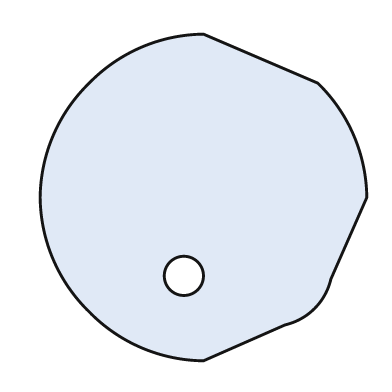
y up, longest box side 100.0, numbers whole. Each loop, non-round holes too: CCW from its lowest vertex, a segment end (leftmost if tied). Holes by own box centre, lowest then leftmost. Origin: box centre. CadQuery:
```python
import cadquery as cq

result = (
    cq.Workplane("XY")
    .moveTo(0.0, -50.0)
    .lineTo(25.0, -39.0)
    .threePointArc((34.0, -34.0), (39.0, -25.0))
    .lineTo(50.0, 0.0)
    .threePointArc((46.0, 19.0), (35.0, 35.0))
    .lineTo(0.0, 50.0)
    .threePointArc((-19.0, 46.0), (-35.0, 35.0))
    .threePointArc((-46.0, 19.0), (-50.0, 0.0))
    .threePointArc((-46.0, -19.0), (-35.0, -35.0))
    .threePointArc((-19.0, -46.0), (0.0, -50.0))
    .close()
    .moveTo(-6.0, -24.0)
    .circle(6.0)
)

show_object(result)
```